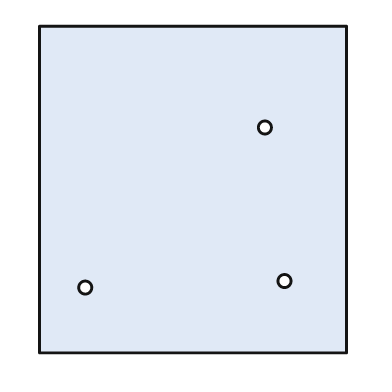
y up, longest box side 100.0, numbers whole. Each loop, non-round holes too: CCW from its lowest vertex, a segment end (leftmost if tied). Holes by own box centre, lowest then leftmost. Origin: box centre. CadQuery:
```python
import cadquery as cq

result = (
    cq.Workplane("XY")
    .moveTo(-47.0, -50.0)
    .lineTo(47.0, -50.0)
    .lineTo(47.0, 50.0)
    .lineTo(-47.0, 50.0)
    .close()
    .moveTo(-33.0, -30.0)
    .circle(2.0)
    .moveTo(28.0, -28.0)
    .circle(2.0)
    .moveTo(22.0, 19.0)
    .circle(2.0)
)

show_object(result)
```